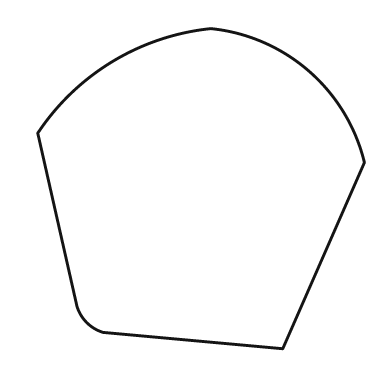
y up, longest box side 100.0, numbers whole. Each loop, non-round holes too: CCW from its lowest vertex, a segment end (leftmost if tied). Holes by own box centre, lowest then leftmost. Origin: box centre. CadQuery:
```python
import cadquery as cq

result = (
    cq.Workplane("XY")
    .moveTo(25.0, -49.0)
    .lineTo(50.0, 8.0)
    .threePointArc((33.0, 36.0), (3.0, 49.0))
    .threePointArc((-27.0, 39.0), (-50.0, 17.0))
    .lineTo(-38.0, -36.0)
    .threePointArc((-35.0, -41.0), (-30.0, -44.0))
    .close()
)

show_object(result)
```